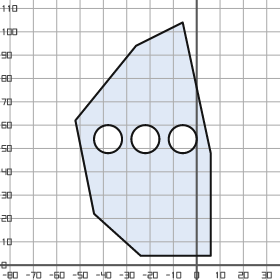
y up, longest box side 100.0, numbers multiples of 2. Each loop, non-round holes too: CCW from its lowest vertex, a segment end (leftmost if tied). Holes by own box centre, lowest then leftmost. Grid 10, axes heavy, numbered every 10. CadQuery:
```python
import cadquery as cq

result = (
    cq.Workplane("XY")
    .moveTo(-24.0, 4.0)
    .lineTo(6.0, 4.0)
    .lineTo(6.0, 48.0)
    .lineTo(-6.0, 104.0)
    .lineTo(-26.0, 94.0)
    .lineTo(-52.0, 62.0)
    .lineTo(-44.0, 22.0)
    .close()
    .moveTo(-38.0, 54.0)
    .circle(6.0)
    .moveTo(-22.0, 54.0)
    .circle(6.0)
    .moveTo(-6.0, 54.0)
    .circle(6.0)
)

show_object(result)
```